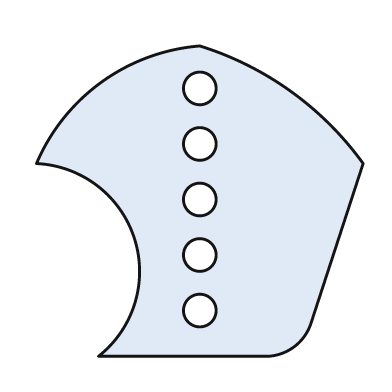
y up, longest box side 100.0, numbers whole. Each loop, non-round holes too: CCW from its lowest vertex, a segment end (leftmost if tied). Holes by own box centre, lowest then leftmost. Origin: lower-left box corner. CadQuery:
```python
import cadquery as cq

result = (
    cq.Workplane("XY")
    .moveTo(19.0, 0.0)
    .lineTo(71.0, 0.0)
    .threePointArc((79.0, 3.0), (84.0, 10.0))
    .lineTo(100.0, 59.0)
    .threePointArc((78.0, 81.0), (50.0, 95.0))
    .threePointArc((20.0, 84.0), (0.0, 59.0))
    .threePointArc((30.0, 36.0), (19.0, 0.0))
    .close()
    .moveTo(50.0, 14.0)
    .circle(5.0)
    .moveTo(50.0, 31.0)
    .circle(5.0)
    .moveTo(50.0, 48.0)
    .circle(5.0)
    .moveTo(50.0, 65.0)
    .circle(5.0)
    .moveTo(50.0, 82.0)
    .circle(5.0)
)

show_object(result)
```